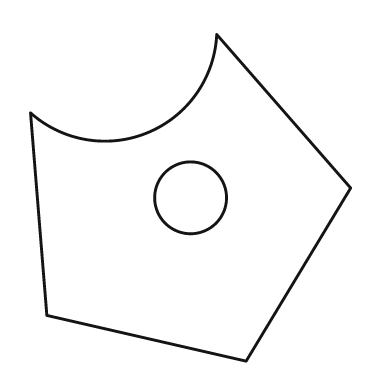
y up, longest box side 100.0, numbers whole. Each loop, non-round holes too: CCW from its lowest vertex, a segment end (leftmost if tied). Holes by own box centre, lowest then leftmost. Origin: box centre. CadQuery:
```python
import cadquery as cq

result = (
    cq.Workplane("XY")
    .moveTo(17.0, -50.0)
    .lineTo(49.0, 3.0)
    .lineTo(8.0, 50.0)
    .threePointArc((-13.0, 20.0), (-49.0, 26.0))
    .lineTo(-44.0, -36.0)
    .close()
    .moveTo(0.0, 0.0)
    .circle(11.0)
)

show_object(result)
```